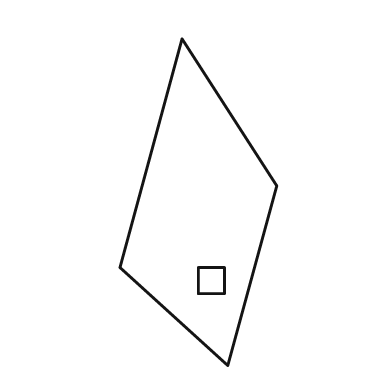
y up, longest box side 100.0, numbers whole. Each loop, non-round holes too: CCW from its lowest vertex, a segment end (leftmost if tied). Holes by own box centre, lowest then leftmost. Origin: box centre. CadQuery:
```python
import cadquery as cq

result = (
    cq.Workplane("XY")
    .moveTo(9.0, -50.0)
    .lineTo(24.0, 5.0)
    .lineTo(-5.0, 50.0)
    .lineTo(-24.0, -20.0)
    .close()
    .moveTo(0.0, -28.0)
    .lineTo(8.0, -28.0)
    .lineTo(8.0, -20.0)
    .lineTo(0.0, -20.0)
    .close()
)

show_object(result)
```